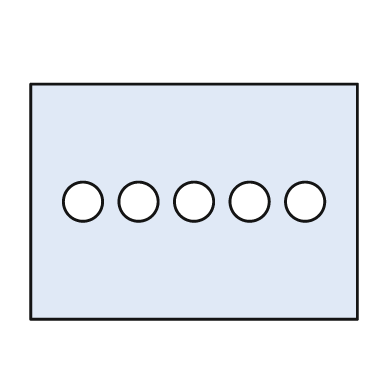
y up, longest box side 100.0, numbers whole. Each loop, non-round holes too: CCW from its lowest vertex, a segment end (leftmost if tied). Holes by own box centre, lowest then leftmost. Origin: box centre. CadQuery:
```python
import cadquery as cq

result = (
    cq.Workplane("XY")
    .moveTo(-50.0, -36.0)
    .lineTo(50.0, -36.0)
    .lineTo(50.0, 36.0)
    .lineTo(-50.0, 36.0)
    .close()
    .moveTo(-34.0, 0.0)
    .circle(6.0)
    .moveTo(-17.0, 0.0)
    .circle(6.0)
    .moveTo(0.0, 0.0)
    .circle(6.0)
    .moveTo(17.0, 0.0)
    .circle(6.0)
    .moveTo(34.0, 0.0)
    .circle(6.0)
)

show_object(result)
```